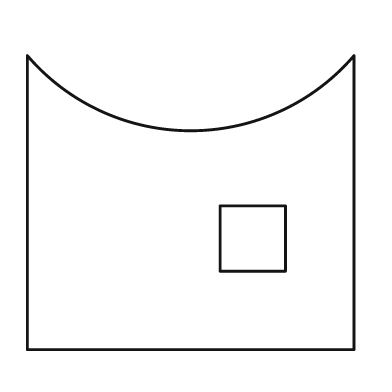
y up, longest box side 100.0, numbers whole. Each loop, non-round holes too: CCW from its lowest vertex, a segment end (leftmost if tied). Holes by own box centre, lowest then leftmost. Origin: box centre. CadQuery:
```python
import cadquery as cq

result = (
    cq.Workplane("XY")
    .moveTo(-50.0, -45.0)
    .lineTo(50.0, -45.0)
    .lineTo(50.0, 45.0)
    .threePointArc((0.0, 22.0), (-50.0, 45.0))
    .close()
    .moveTo(9.0, -21.0)
    .lineTo(29.0, -21.0)
    .lineTo(29.0, -1.0)
    .lineTo(9.0, -1.0)
    .close()
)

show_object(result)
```